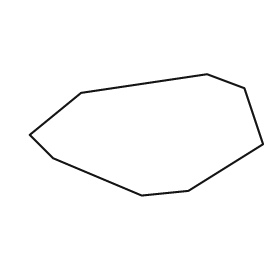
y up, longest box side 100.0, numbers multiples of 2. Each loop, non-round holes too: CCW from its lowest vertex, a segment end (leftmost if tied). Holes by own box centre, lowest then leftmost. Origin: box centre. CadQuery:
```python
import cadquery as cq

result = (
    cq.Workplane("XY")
    .moveTo(-2.0, -26.0)
    .lineTo(18.0, -24.0)
    .lineTo(50.0, -4.0)
    .lineTo(42.0, 20.0)
    .lineTo(26.0, 26.0)
    .lineTo(-28.0, 18.0)
    .lineTo(-50.0, 0.0)
    .lineTo(-40.0, -10.0)
    .close()
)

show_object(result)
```